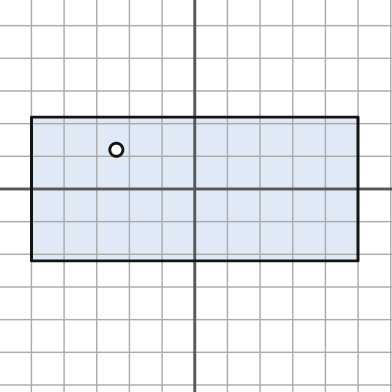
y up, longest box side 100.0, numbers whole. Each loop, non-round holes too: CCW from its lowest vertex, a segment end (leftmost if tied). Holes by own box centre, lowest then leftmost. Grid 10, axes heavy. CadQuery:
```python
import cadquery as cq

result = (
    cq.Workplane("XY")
    .moveTo(-50.0, -22.0)
    .lineTo(50.0, -22.0)
    .lineTo(50.0, 22.0)
    .lineTo(-50.0, 22.0)
    .close()
    .moveTo(-24.0, 12.0)
    .circle(2.0)
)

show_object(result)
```